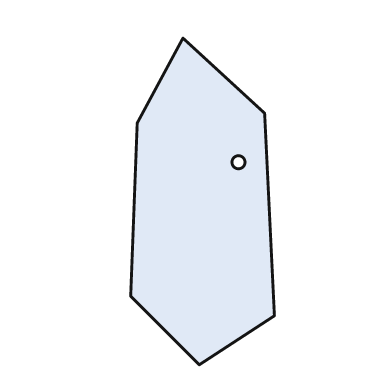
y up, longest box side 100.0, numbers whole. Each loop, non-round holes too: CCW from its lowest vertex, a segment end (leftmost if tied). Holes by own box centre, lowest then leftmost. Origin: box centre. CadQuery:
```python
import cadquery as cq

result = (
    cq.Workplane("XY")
    .moveTo(-1.0, -50.0)
    .lineTo(22.0, -35.0)
    .lineTo(19.0, 27.0)
    .lineTo(-6.0, 50.0)
    .lineTo(-20.0, 24.0)
    .lineTo(-22.0, -29.0)
    .close()
    .moveTo(11.0, 12.0)
    .circle(2.0)
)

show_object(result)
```